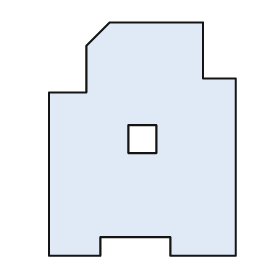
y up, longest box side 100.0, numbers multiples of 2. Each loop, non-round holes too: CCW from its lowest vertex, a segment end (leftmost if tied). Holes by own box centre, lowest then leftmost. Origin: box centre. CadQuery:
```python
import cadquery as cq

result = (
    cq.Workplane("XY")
    .moveTo(-40.0, -50.0)
    .lineTo(-18.0, -50.0)
    .lineTo(-18.0, -42.0)
    .lineTo(12.0, -42.0)
    .lineTo(12.0, -50.0)
    .lineTo(40.0, -50.0)
    .lineTo(40.0, 26.0)
    .lineTo(26.0, 26.0)
    .lineTo(26.0, 50.0)
    .lineTo(-14.0, 50.0)
    .lineTo(-24.0, 40.0)
    .lineTo(-24.0, 20.0)
    .lineTo(-40.0, 20.0)
    .close()
    .moveTo(-6.0, -6.0)
    .lineTo(6.0, -6.0)
    .lineTo(6.0, 6.0)
    .lineTo(-6.0, 6.0)
    .close()
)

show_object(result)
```